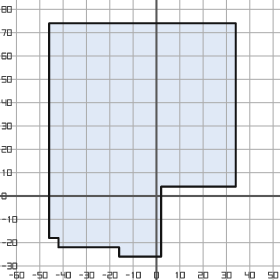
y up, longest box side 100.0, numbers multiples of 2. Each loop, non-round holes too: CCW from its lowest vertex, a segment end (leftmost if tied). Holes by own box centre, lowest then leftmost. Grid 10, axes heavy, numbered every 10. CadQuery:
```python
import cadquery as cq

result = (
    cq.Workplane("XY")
    .moveTo(-16.0, -26.0)
    .lineTo(2.0, -26.0)
    .lineTo(2.0, 4.0)
    .lineTo(34.0, 4.0)
    .lineTo(34.0, 74.0)
    .lineTo(-46.0, 74.0)
    .lineTo(-46.0, -18.0)
    .lineTo(-42.0, -18.0)
    .lineTo(-42.0, -22.0)
    .lineTo(-16.0, -22.0)
    .close()
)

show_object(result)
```